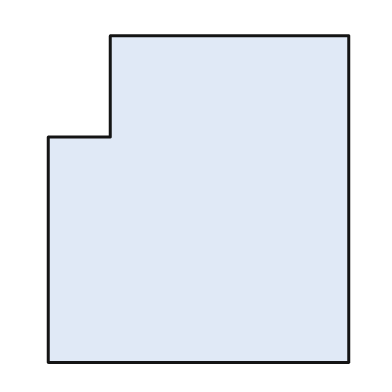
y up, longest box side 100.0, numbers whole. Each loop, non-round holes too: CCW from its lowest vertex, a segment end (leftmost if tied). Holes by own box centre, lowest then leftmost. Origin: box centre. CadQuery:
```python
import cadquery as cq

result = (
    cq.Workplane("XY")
    .moveTo(-46.0, -50.0)
    .lineTo(46.0, -50.0)
    .lineTo(46.0, 50.0)
    .lineTo(-27.0, 50.0)
    .lineTo(-27.0, 19.0)
    .lineTo(-46.0, 19.0)
    .close()
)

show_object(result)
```